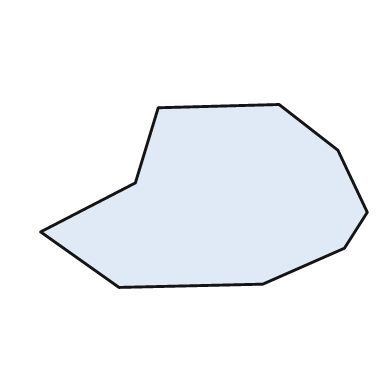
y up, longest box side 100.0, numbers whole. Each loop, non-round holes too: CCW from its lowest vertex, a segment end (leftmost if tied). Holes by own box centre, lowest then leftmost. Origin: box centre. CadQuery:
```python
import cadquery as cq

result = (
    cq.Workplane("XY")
    .moveTo(-26.0, -28.0)
    .lineTo(18.0, -27.0)
    .lineTo(43.0, -16.0)
    .lineTo(50.0, -5.0)
    .lineTo(41.0, 14.0)
    .lineTo(23.0, 28.0)
    .lineTo(-14.0, 27.0)
    .lineTo(-21.0, 4.0)
    .lineTo(-50.0, -11.0)
    .close()
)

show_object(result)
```